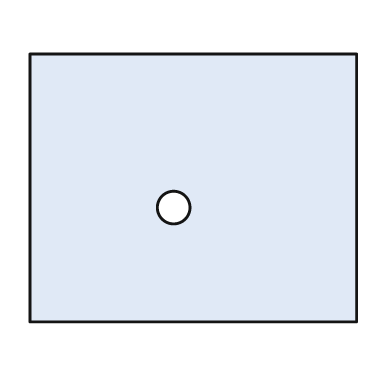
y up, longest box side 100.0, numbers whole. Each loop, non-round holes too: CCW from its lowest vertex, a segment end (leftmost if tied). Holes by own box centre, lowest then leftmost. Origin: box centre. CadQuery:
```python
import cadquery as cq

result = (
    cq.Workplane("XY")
    .moveTo(-50.0, -41.0)
    .lineTo(50.0, -41.0)
    .lineTo(50.0, 41.0)
    .lineTo(-50.0, 41.0)
    .close()
    .moveTo(-6.0, -6.0)
    .circle(5.0)
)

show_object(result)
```